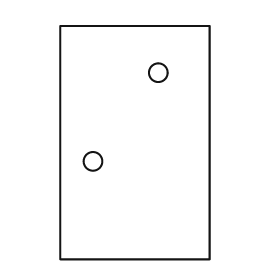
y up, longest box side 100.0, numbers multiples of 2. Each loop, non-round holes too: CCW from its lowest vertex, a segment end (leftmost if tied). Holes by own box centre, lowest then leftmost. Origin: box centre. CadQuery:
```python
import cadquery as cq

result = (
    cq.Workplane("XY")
    .moveTo(-32.0, -50.0)
    .lineTo(32.0, -50.0)
    .lineTo(32.0, 50.0)
    .lineTo(-32.0, 50.0)
    .close()
    .moveTo(-18.0, -8.0)
    .circle(4.0)
    .moveTo(10.0, 30.0)
    .circle(4.0)
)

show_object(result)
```